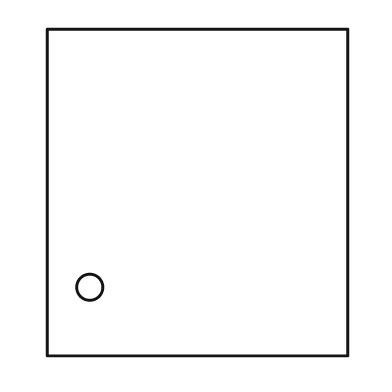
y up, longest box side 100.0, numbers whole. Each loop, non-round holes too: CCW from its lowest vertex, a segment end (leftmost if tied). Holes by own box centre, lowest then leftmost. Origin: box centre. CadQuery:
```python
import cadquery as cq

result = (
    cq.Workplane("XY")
    .moveTo(-46.0, -50.0)
    .lineTo(46.0, -50.0)
    .lineTo(46.0, 50.0)
    .lineTo(-46.0, 50.0)
    .close()
    .moveTo(-33.0, -29.0)
    .circle(4.0)
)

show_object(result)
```